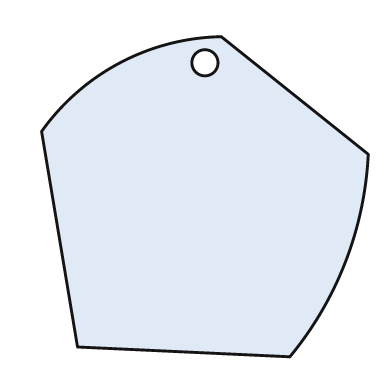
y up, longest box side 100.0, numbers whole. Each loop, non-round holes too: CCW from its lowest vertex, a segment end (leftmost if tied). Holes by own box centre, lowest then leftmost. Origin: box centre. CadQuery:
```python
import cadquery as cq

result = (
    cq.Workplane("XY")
    .moveTo(26.0, -49.0)
    .threePointArc((43.0, -20.0), (50.0, 13.0))
    .lineTo(5.0, 49.0)
    .threePointArc((-26.0, 41.0), (-50.0, 20.0))
    .lineTo(-39.0, -46.0)
    .close()
    .moveTo(0.0, 41.0)
    .circle(4.0)
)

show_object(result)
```